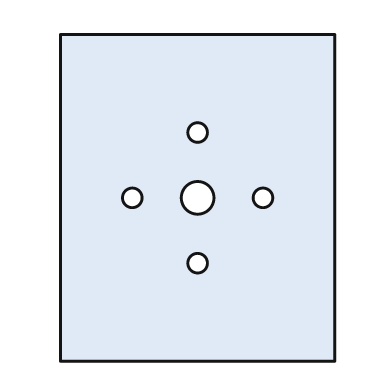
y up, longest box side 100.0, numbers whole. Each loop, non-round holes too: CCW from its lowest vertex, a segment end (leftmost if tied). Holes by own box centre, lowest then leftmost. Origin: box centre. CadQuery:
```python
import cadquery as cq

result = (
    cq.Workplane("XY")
    .moveTo(-42.0, -50.0)
    .lineTo(42.0, -50.0)
    .lineTo(42.0, 50.0)
    .lineTo(-42.0, 50.0)
    .close()
    .moveTo(0.0, -20.0)
    .circle(3.0)
    .moveTo(-20.0, 0.0)
    .circle(3.0)
    .moveTo(0.0, 0.0)
    .circle(5.0)
    .moveTo(20.0, 0.0)
    .circle(3.0)
    .moveTo(0.0, 20.0)
    .circle(3.0)
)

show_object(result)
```